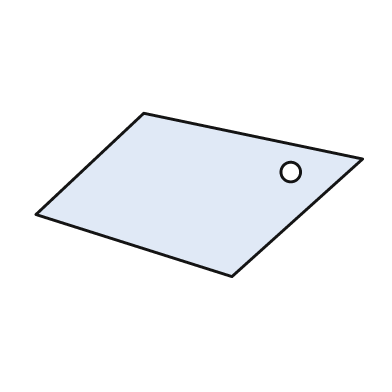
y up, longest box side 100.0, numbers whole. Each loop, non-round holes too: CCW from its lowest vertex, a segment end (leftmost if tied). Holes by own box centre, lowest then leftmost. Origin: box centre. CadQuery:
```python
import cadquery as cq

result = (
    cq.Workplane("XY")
    .moveTo(10.0, -25.0)
    .lineTo(50.0, 11.0)
    .lineTo(-17.0, 25.0)
    .lineTo(-50.0, -6.0)
    .close()
    .moveTo(28.0, 7.0)
    .circle(3.0)
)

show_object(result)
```